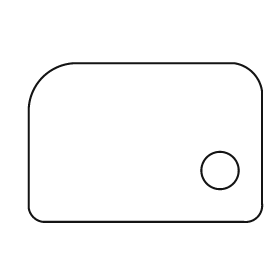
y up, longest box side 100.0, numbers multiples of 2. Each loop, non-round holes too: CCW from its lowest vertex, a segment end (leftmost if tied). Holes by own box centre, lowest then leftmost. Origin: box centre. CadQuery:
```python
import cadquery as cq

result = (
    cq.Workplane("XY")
    .moveTo(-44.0, -34.0)
    .lineTo(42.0, -34.0)
    .threePointArc((48.0, -32.0), (50.0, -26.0))
    .lineTo(50.0, 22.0)
    .threePointArc((46.0, 30.0), (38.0, 34.0))
    .lineTo(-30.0, 34.0)
    .threePointArc((-44.0, 28.0), (-50.0, 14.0))
    .lineTo(-50.0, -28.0)
    .threePointArc((-48.0, -32.0), (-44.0, -34.0))
    .close()
    .moveTo(32.0, -12.0)
    .circle(8.0)
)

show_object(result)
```